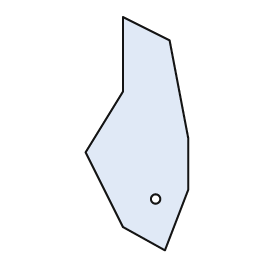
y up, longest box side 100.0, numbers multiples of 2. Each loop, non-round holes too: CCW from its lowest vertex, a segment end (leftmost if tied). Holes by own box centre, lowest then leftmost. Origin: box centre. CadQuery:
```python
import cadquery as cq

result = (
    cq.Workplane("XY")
    .moveTo(12.0, -50.0)
    .lineTo(22.0, -24.0)
    .lineTo(22.0, -2.0)
    .lineTo(14.0, 40.0)
    .lineTo(-6.0, 50.0)
    .lineTo(-6.0, 18.0)
    .lineTo(-22.0, -8.0)
    .lineTo(-6.0, -40.0)
    .close()
    .moveTo(8.0, -28.0)
    .circle(2.0)
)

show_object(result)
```